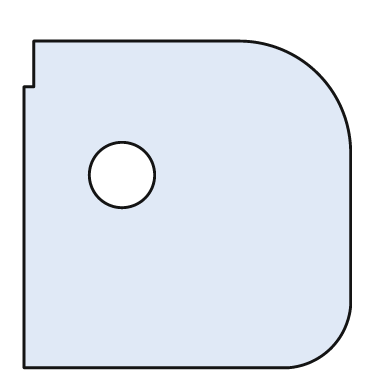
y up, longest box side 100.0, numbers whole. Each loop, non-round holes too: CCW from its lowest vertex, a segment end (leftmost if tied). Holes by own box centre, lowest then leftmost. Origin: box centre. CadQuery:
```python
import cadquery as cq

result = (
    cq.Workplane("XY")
    .moveTo(-50.0, -50.0)
    .lineTo(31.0, -50.0)
    .threePointArc((44.0, -44.0), (50.0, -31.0))
    .lineTo(50.0, 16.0)
    .threePointArc((40.0, 40.0), (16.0, 50.0))
    .lineTo(-47.0, 50.0)
    .lineTo(-47.0, 36.0)
    .lineTo(-50.0, 36.0)
    .close()
    .moveTo(-20.0, 9.0)
    .circle(10.0)
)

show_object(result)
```